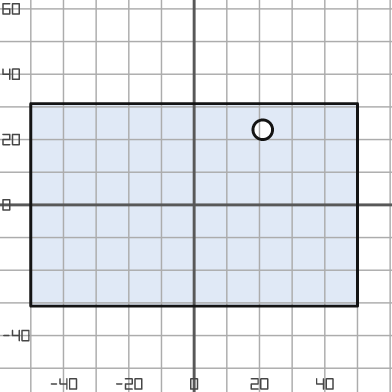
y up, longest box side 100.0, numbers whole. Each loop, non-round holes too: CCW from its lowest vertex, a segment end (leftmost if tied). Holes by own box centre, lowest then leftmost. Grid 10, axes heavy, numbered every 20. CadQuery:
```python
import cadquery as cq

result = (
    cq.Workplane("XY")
    .moveTo(-50.0, -31.0)
    .lineTo(50.0, -31.0)
    .lineTo(50.0, 31.0)
    .lineTo(-50.0, 31.0)
    .close()
    .moveTo(21.0, 23.0)
    .circle(3.0)
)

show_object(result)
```